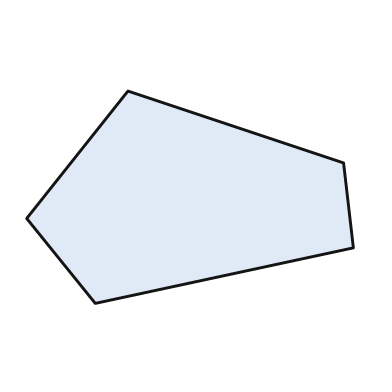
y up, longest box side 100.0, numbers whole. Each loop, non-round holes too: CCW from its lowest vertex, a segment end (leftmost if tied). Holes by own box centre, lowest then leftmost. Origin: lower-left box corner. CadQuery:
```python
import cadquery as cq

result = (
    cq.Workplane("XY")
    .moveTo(21.0, 0.0)
    .lineTo(100.0, 17.0)
    .lineTo(97.0, 43.0)
    .lineTo(31.0, 65.0)
    .lineTo(0.0, 26.0)
    .close()
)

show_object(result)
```